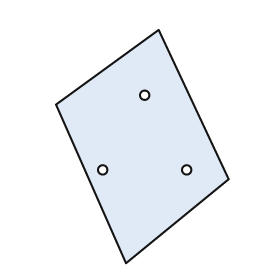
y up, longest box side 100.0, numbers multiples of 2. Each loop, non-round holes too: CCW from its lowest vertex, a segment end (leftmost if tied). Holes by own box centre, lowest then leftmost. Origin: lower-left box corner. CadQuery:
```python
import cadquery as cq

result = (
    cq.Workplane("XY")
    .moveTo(30.0, 0.0)
    .lineTo(74.0, 36.0)
    .lineTo(44.0, 100.0)
    .lineTo(0.0, 68.0)
    .close()
    .moveTo(20.0, 40.0)
    .circle(2.0)
    .moveTo(56.0, 40.0)
    .circle(2.0)
    .moveTo(38.0, 72.0)
    .circle(2.0)
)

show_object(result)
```